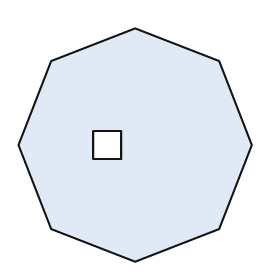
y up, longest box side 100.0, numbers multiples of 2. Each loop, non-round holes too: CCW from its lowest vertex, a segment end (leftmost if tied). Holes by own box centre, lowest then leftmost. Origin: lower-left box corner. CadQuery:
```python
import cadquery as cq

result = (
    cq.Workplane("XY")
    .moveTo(50.0, 0.0)
    .lineTo(86.0, 14.0)
    .lineTo(100.0, 50.0)
    .lineTo(86.0, 86.0)
    .lineTo(50.0, 100.0)
    .lineTo(14.0, 86.0)
    .lineTo(0.0, 50.0)
    .lineTo(14.0, 14.0)
    .close()
    .moveTo(32.0, 44.0)
    .lineTo(44.0, 44.0)
    .lineTo(44.0, 56.0)
    .lineTo(32.0, 56.0)
    .close()
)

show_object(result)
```